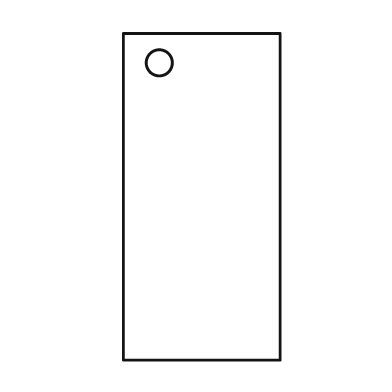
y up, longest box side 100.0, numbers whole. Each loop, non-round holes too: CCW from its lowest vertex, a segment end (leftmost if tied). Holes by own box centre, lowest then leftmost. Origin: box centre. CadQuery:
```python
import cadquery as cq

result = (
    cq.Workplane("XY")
    .moveTo(-24.0, -50.0)
    .lineTo(24.0, -50.0)
    .lineTo(24.0, 50.0)
    .lineTo(-24.0, 50.0)
    .close()
    .moveTo(-13.0, 41.0)
    .circle(4.0)
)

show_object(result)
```